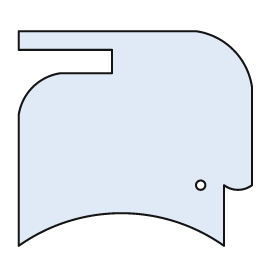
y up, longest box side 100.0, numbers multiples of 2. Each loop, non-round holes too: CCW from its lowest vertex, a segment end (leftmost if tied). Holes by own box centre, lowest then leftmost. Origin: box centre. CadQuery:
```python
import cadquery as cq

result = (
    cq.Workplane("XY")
    .moveTo(-50.0, -46.0)
    .threePointArc((-6.0, -32.0), (38.0, -46.0))
    .lineTo(38.0, -20.0)
    .threePointArc((44.0, -22.0), (50.0, -20.0))
    .lineTo(50.0, 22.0)
    .threePointArc((42.0, 38.0), (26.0, 46.0))
    .lineTo(-50.0, 46.0)
    .lineTo(-50.0, 38.0)
    .lineTo(-10.0, 38.0)
    .lineTo(-10.0, 28.0)
    .lineTo(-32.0, 28.0)
    .threePointArc((-44.0, 22.0), (-50.0, 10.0))
    .close()
    .moveTo(28.0, -20.0)
    .circle(2.0)
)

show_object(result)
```